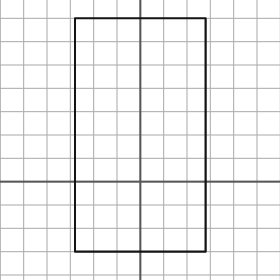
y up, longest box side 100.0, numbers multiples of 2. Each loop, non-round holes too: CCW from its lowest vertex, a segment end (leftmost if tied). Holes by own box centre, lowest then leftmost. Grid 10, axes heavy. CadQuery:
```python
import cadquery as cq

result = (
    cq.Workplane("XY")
    .moveTo(-28.0, -30.0)
    .lineTo(28.0, -30.0)
    .lineTo(28.0, 70.0)
    .lineTo(-28.0, 70.0)
    .close()
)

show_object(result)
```